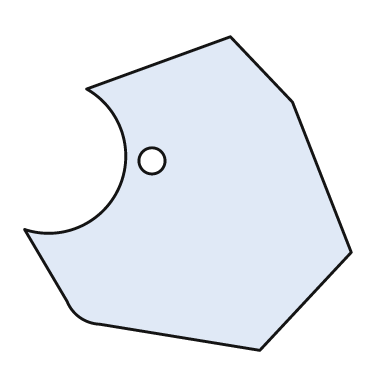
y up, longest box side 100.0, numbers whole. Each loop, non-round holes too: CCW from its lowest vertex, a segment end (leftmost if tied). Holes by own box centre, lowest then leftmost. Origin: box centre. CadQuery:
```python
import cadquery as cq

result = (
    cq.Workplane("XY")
    .moveTo(22.0, -48.0)
    .lineTo(50.0, -18.0)
    .lineTo(32.0, 28.0)
    .lineTo(13.0, 48.0)
    .lineTo(-31.0, 32.0)
    .threePointArc((-21.0, 2.0), (-50.0, -11.0))
    .lineTo(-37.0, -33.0)
    .threePointArc((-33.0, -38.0), (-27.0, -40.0))
    .close()
    .moveTo(-11.0, 10.0)
    .circle(4.0)
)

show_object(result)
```